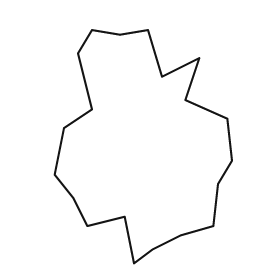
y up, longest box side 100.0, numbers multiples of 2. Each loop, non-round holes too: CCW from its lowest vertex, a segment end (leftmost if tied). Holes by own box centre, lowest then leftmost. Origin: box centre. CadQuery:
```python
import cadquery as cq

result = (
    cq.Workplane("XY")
    .moveTo(-4.0, -50.0)
    .lineTo(4.0, -44.0)
    .lineTo(16.0, -38.0)
    .lineTo(30.0, -34.0)
    .lineTo(32.0, -16.0)
    .lineTo(38.0, -6.0)
    .lineTo(36.0, 12.0)
    .lineTo(18.0, 20.0)
    .lineTo(24.0, 38.0)
    .lineTo(8.0, 30.0)
    .lineTo(2.0, 50.0)
    .lineTo(-10.0, 48.0)
    .lineTo(-22.0, 50.0)
    .lineTo(-28.0, 40.0)
    .lineTo(-22.0, 16.0)
    .lineTo(-34.0, 8.0)
    .lineTo(-38.0, -12.0)
    .lineTo(-30.0, -22.0)
    .lineTo(-24.0, -34.0)
    .lineTo(-8.0, -30.0)
    .close()
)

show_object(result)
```